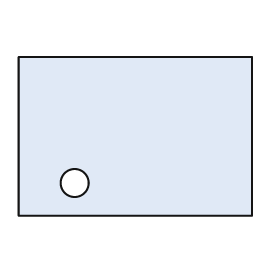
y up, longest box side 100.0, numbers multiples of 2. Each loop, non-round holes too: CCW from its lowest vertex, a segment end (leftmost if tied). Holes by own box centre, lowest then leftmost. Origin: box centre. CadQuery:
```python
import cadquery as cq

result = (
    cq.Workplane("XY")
    .moveTo(-50.0, -34.0)
    .lineTo(50.0, -34.0)
    .lineTo(50.0, 34.0)
    .lineTo(-50.0, 34.0)
    .close()
    .moveTo(-26.0, -20.0)
    .circle(6.0)
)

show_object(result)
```